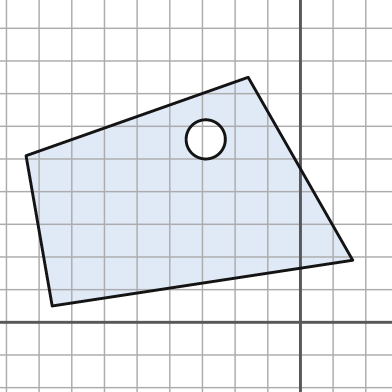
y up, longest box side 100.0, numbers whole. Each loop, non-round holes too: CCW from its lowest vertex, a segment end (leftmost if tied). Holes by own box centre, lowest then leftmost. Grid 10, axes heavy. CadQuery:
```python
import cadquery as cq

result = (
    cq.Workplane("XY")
    .moveTo(-76.0, 5.0)
    .lineTo(16.0, 19.0)
    .lineTo(-16.0, 75.0)
    .lineTo(-84.0, 51.0)
    .close()
    .moveTo(-29.0, 56.0)
    .circle(6.0)
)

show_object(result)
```